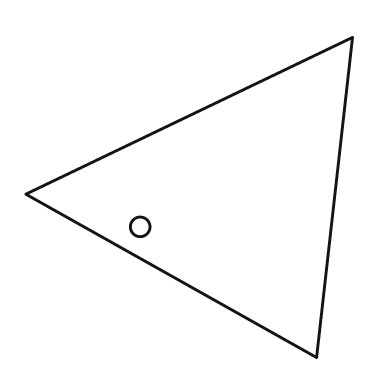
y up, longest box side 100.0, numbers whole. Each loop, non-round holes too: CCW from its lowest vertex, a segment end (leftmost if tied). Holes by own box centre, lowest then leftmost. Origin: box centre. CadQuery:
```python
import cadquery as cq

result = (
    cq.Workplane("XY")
    .moveTo(39.0, -49.0)
    .lineTo(50.0, 49.0)
    .lineTo(-50.0, 1.0)
    .close()
    .moveTo(-15.0, -9.0)
    .circle(3.0)
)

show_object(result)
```